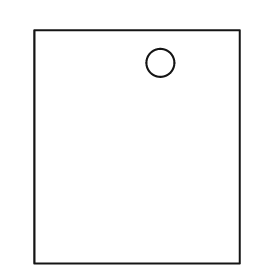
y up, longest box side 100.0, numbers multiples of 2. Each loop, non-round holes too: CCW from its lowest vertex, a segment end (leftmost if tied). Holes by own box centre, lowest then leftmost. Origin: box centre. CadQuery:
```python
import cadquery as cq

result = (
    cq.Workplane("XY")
    .moveTo(-44.0, -50.0)
    .lineTo(44.0, -50.0)
    .lineTo(44.0, 50.0)
    .lineTo(-44.0, 50.0)
    .close()
    .moveTo(10.0, 36.0)
    .circle(6.0)
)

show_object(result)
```